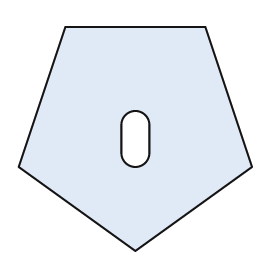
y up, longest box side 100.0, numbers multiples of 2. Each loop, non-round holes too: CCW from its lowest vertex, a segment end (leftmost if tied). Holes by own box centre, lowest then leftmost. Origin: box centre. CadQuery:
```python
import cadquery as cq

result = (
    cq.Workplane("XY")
    .moveTo(0.0, -48.0)
    .lineTo(50.0, -12.0)
    .lineTo(30.0, 48.0)
    .lineTo(-30.0, 48.0)
    .lineTo(-50.0, -12.0)
    .close()
    .moveTo(-6.0, -6.0)
    .threePointArc((0.0, -12.0), (6.0, -6.0))
    .lineTo(6.0, 6.0)
    .threePointArc((0.0, 12.0), (-6.0, 6.0))
    .close()
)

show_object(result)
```